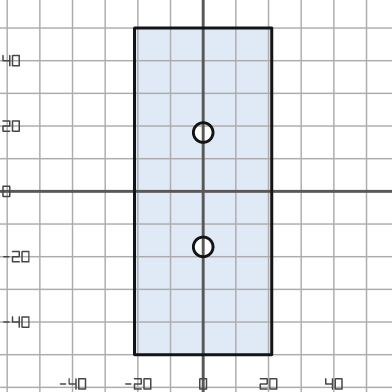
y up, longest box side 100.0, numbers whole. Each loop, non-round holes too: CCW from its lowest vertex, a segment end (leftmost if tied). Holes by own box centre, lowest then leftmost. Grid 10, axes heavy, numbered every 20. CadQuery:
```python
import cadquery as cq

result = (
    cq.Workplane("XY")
    .moveTo(-21.0, -50.0)
    .lineTo(21.0, -50.0)
    .lineTo(21.0, 50.0)
    .lineTo(-21.0, 50.0)
    .close()
    .moveTo(0.0, -17.0)
    .circle(3.0)
    .moveTo(0.0, 18.0)
    .circle(3.0)
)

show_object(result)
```